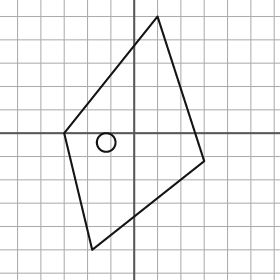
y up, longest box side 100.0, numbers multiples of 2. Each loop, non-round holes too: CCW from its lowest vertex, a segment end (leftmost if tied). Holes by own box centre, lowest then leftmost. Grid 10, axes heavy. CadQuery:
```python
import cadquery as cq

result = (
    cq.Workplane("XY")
    .moveTo(-18.0, -50.0)
    .lineTo(30.0, -12.0)
    .lineTo(10.0, 50.0)
    .lineTo(-30.0, 0.0)
    .close()
    .moveTo(-12.0, -4.0)
    .circle(4.0)
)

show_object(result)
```